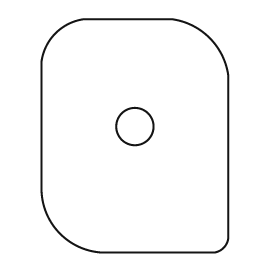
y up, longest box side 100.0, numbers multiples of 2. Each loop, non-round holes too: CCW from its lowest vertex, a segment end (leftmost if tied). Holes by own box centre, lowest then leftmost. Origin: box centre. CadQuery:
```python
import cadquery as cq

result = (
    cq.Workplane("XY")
    .moveTo(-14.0, -50.0)
    .lineTo(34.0, -50.0)
    .threePointArc((38.0, -48.0), (40.0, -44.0))
    .lineTo(40.0, 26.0)
    .threePointArc((32.0, 42.0), (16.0, 50.0))
    .lineTo(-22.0, 50.0)
    .threePointArc((-34.0, 44.0), (-40.0, 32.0))
    .lineTo(-40.0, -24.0)
    .threePointArc((-32.0, -42.0), (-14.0, -50.0))
    .close()
    .moveTo(0.0, 4.0)
    .circle(8.0)
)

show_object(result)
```